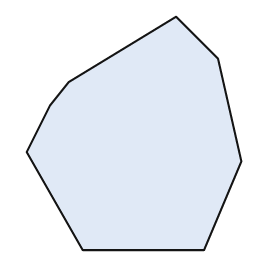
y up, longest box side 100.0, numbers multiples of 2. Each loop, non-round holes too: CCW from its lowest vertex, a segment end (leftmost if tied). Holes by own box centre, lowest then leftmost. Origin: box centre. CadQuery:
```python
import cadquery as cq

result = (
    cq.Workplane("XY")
    .moveTo(-22.0, -50.0)
    .lineTo(30.0, -50.0)
    .lineTo(46.0, -12.0)
    .lineTo(36.0, 32.0)
    .lineTo(18.0, 50.0)
    .lineTo(-28.0, 22.0)
    .lineTo(-36.0, 12.0)
    .lineTo(-46.0, -8.0)
    .close()
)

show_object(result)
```